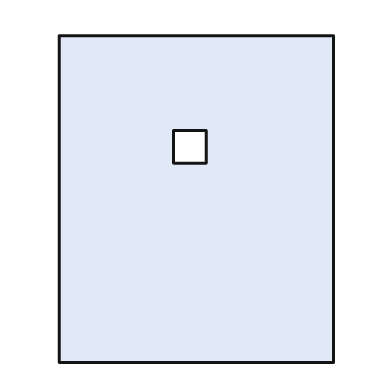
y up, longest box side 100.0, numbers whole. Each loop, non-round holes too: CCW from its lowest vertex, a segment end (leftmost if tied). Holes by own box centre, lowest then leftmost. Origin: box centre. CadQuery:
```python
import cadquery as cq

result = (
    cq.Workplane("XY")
    .moveTo(-42.0, -50.0)
    .lineTo(42.0, -50.0)
    .lineTo(42.0, 50.0)
    .lineTo(-42.0, 50.0)
    .close()
    .moveTo(-7.0, 11.0)
    .lineTo(3.0, 11.0)
    .lineTo(3.0, 21.0)
    .lineTo(-7.0, 21.0)
    .close()
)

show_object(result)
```